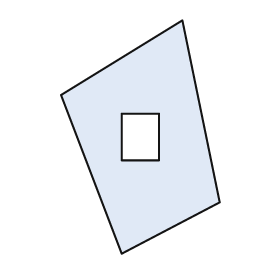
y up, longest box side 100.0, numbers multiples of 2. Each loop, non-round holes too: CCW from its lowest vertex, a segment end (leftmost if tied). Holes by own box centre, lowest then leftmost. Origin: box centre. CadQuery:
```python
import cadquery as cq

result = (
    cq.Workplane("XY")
    .moveTo(-8.0, -50.0)
    .lineTo(34.0, -28.0)
    .lineTo(18.0, 50.0)
    .lineTo(-34.0, 18.0)
    .close()
    .moveTo(-8.0, -10.0)
    .lineTo(8.0, -10.0)
    .lineTo(8.0, 10.0)
    .lineTo(-8.0, 10.0)
    .close()
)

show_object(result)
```